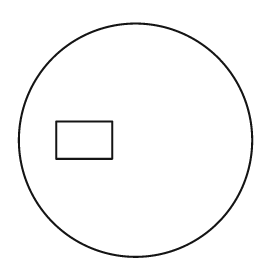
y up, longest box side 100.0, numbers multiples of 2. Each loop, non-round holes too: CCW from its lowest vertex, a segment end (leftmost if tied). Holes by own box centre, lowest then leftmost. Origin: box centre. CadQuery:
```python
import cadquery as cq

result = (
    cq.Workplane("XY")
    .moveTo(0.0, 0.0)
    .circle(50.0)
    .moveTo(-34.0, -8.0)
    .lineTo(-10.0, -8.0)
    .lineTo(-10.0, 8.0)
    .lineTo(-34.0, 8.0)
    .close()
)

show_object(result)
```